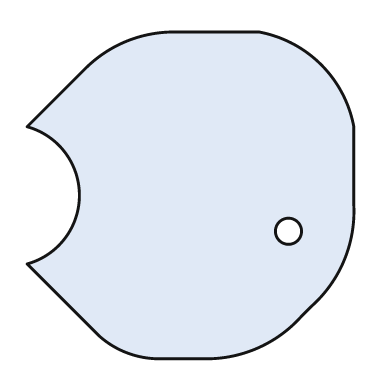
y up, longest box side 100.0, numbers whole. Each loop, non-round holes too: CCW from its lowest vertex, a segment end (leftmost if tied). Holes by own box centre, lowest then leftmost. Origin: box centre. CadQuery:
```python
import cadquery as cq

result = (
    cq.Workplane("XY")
    .moveTo(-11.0, -50.0)
    .lineTo(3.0, -50.0)
    .threePointArc((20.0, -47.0), (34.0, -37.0))
    .lineTo(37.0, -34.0)
    .threePointArc((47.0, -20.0), (50.0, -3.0))
    .lineTo(50.0, 21.0)
    .threePointArc((40.0, 40.0), (21.0, 50.0))
    .lineTo(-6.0, 50.0)
    .threePointArc((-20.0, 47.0), (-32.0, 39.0))
    .lineTo(-50.0, 21.0)
    .threePointArc((-34.0, 0.0), (-50.0, -21.0))
    .lineTo(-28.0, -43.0)
    .threePointArc((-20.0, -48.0), (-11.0, -50.0))
    .close()
    .moveTo(30.0, -11.0)
    .circle(4.0)
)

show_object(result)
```